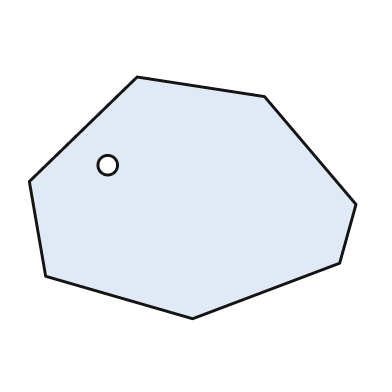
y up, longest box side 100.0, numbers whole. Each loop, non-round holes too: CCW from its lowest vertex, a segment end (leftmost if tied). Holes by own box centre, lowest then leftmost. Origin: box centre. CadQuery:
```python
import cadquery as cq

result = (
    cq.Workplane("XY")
    .moveTo(0.0, -37.0)
    .lineTo(45.0, -20.0)
    .lineTo(50.0, -2.0)
    .lineTo(22.0, 31.0)
    .lineTo(-17.0, 37.0)
    .lineTo(-50.0, 5.0)
    .lineTo(-45.0, -24.0)
    .close()
    .moveTo(-26.0, 10.0)
    .circle(3.0)
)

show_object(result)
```